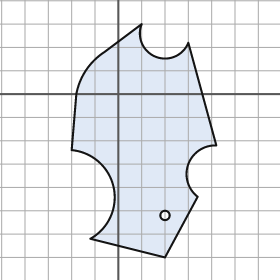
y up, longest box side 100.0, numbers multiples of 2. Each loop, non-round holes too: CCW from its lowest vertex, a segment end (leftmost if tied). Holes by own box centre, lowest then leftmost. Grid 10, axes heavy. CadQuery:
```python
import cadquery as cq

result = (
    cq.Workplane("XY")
    .moveTo(20.0, -70.0)
    .lineTo(34.0, -44.0)
    .threePointArc((30.0, -30.0), (42.0, -22.0))
    .lineTo(30.0, 22.0)
    .threePointArc((16.0, 16.0), (10.0, 30.0))
    .lineTo(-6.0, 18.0)
    .threePointArc((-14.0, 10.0), (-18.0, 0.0))
    .lineTo(-20.0, -24.0)
    .threePointArc((-2.0, -40.0), (-12.0, -62.0))
    .close()
    .moveTo(20.0, -52.0)
    .circle(2.0)
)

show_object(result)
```